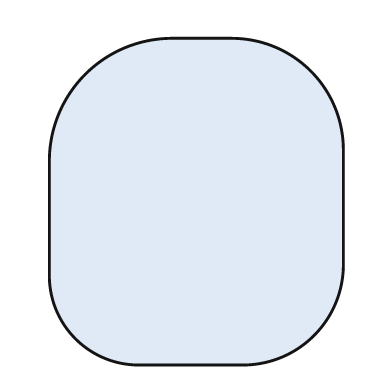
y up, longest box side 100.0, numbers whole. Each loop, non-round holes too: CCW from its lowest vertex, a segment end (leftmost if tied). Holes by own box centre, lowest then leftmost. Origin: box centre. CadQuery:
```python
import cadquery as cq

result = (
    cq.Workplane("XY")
    .moveTo(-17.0, -50.0)
    .lineTo(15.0, -50.0)
    .threePointArc((36.0, -41.0), (45.0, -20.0))
    .lineTo(45.0, 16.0)
    .threePointArc((35.0, 40.0), (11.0, 50.0))
    .lineTo(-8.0, 50.0)
    .threePointArc((-34.0, 39.0), (-45.0, 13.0))
    .lineTo(-45.0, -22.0)
    .threePointArc((-37.0, -42.0), (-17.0, -50.0))
    .close()
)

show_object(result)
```